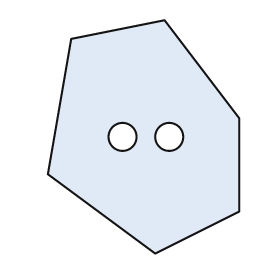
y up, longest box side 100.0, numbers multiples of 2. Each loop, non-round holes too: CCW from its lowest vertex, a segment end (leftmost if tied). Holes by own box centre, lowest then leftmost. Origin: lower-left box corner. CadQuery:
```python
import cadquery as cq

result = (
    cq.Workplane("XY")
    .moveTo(46.0, 0.0)
    .lineTo(82.0, 18.0)
    .lineTo(82.0, 58.0)
    .lineTo(50.0, 100.0)
    .lineTo(10.0, 92.0)
    .lineTo(0.0, 34.0)
    .close()
    .moveTo(32.0, 50.0)
    .circle(6.0)
    .moveTo(52.0, 50.0)
    .circle(6.0)
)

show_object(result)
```